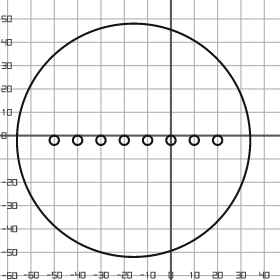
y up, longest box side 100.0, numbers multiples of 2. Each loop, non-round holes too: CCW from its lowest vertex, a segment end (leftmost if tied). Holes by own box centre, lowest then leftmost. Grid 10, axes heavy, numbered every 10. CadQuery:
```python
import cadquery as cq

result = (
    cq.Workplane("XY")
    .moveTo(-16.0, -2.0)
    .circle(50.0)
    .moveTo(-50.0, -2.0)
    .circle(2.0)
    .moveTo(-40.0, -2.0)
    .circle(2.0)
    .moveTo(-30.0, -2.0)
    .circle(2.0)
    .moveTo(-20.0, -2.0)
    .circle(2.0)
    .moveTo(-10.0, -2.0)
    .circle(2.0)
    .moveTo(0.0, -2.0)
    .circle(2.0)
    .moveTo(10.0, -2.0)
    .circle(2.0)
    .moveTo(20.0, -2.0)
    .circle(2.0)
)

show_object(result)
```